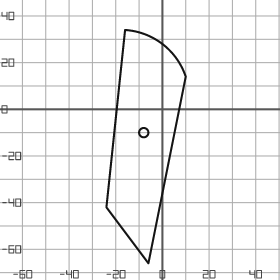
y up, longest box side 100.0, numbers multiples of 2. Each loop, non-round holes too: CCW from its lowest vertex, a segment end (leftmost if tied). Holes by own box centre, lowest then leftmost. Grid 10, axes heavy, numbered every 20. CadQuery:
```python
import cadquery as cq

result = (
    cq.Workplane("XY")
    .moveTo(-6.0, -66.0)
    .lineTo(10.0, 14.0)
    .threePointArc((0.0, 28.0), (-16.0, 34.0))
    .lineTo(-24.0, -42.0)
    .close()
    .moveTo(-8.0, -10.0)
    .circle(2.0)
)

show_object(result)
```